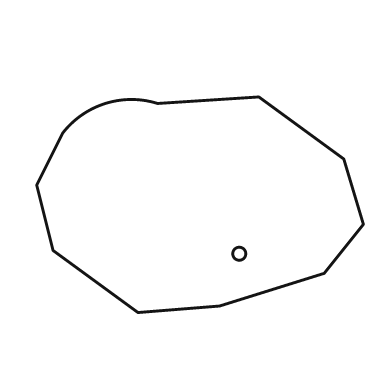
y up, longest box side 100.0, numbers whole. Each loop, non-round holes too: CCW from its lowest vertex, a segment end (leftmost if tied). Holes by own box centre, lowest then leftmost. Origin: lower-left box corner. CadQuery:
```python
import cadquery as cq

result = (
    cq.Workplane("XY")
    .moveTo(31.0, 0.0)
    .lineTo(56.0, 2.0)
    .lineTo(88.0, 12.0)
    .lineTo(100.0, 27.0)
    .lineTo(94.0, 47.0)
    .lineTo(68.0, 66.0)
    .lineTo(37.0, 64.0)
    .threePointArc((21.0, 64.0), (8.0, 55.0))
    .lineTo(0.0, 39.0)
    .lineTo(5.0, 19.0)
    .close()
    .moveTo(62.0, 18.0)
    .circle(2.0)
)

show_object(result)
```